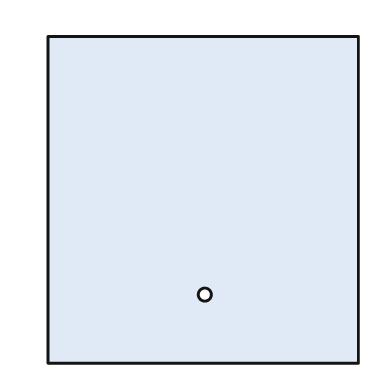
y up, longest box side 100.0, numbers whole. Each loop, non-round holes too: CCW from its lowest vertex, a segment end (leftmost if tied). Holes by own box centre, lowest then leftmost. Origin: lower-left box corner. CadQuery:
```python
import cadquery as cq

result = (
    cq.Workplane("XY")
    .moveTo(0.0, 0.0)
    .lineTo(95.0, 0.0)
    .lineTo(95.0, 100.0)
    .lineTo(0.0, 100.0)
    .close()
    .moveTo(48.0, 21.0)
    .circle(2.0)
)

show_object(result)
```